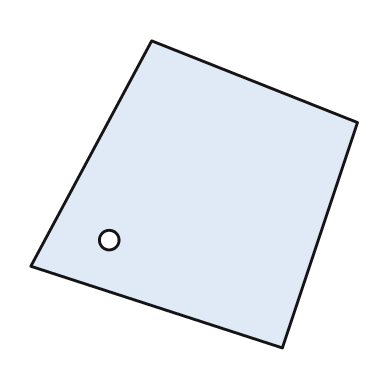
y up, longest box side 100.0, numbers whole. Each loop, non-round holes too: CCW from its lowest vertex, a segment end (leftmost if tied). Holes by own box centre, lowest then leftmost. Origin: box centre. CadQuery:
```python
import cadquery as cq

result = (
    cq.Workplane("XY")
    .moveTo(27.0, -47.0)
    .lineTo(50.0, 22.0)
    .lineTo(-13.0, 47.0)
    .lineTo(-50.0, -22.0)
    .close()
    .moveTo(-26.0, -14.0)
    .circle(3.0)
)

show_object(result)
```